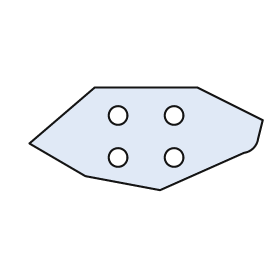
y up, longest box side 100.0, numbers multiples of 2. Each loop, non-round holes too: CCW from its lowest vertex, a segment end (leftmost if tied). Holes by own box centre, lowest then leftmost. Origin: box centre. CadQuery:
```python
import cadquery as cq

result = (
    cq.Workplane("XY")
    .moveTo(6.0, -22.0)
    .lineTo(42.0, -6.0)
    .threePointArc((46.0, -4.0), (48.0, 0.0))
    .lineTo(50.0, 8.0)
    .lineTo(22.0, 22.0)
    .lineTo(-22.0, 22.0)
    .lineTo(-50.0, -2.0)
    .lineTo(-26.0, -16.0)
    .close()
    .moveTo(-12.0, -8.0)
    .circle(4.0)
    .moveTo(12.0, -8.0)
    .circle(4.0)
    .moveTo(-12.0, 10.0)
    .circle(4.0)
    .moveTo(12.0, 10.0)
    .circle(4.0)
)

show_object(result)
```